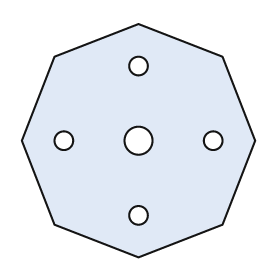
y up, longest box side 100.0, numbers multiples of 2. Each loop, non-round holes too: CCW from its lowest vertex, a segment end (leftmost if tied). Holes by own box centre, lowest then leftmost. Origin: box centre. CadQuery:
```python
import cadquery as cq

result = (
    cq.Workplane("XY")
    .moveTo(0.0, -50.0)
    .lineTo(36.0, -36.0)
    .lineTo(50.0, 0.0)
    .lineTo(36.0, 36.0)
    .lineTo(0.0, 50.0)
    .lineTo(-36.0, 36.0)
    .lineTo(-50.0, 0.0)
    .lineTo(-36.0, -36.0)
    .close()
    .moveTo(0.0, -32.0)
    .circle(4.0)
    .moveTo(-32.0, 0.0)
    .circle(4.0)
    .moveTo(0.0, 0.0)
    .circle(6.0)
    .moveTo(32.0, 0.0)
    .circle(4.0)
    .moveTo(0.0, 32.0)
    .circle(4.0)
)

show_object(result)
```